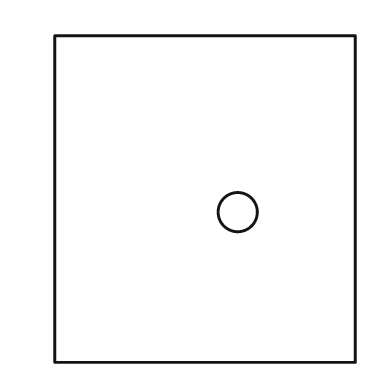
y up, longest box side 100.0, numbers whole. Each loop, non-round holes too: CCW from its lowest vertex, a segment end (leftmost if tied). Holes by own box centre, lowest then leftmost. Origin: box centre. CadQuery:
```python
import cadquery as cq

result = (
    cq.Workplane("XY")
    .moveTo(-46.0, -50.0)
    .lineTo(46.0, -50.0)
    .lineTo(46.0, 50.0)
    .lineTo(-46.0, 50.0)
    .close()
    .moveTo(10.0, -4.0)
    .circle(6.0)
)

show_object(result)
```